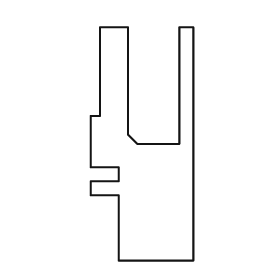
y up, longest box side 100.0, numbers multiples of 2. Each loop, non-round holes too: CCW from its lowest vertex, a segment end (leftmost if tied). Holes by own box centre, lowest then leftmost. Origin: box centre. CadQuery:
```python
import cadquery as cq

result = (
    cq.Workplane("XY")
    .moveTo(-10.0, -50.0)
    .lineTo(22.0, -50.0)
    .lineTo(22.0, 50.0)
    .lineTo(16.0, 50.0)
    .lineTo(16.0, 0.0)
    .lineTo(-2.0, 0.0)
    .lineTo(-6.0, 4.0)
    .lineTo(-6.0, 50.0)
    .lineTo(-18.0, 50.0)
    .lineTo(-18.0, 12.0)
    .lineTo(-22.0, 12.0)
    .lineTo(-22.0, -10.0)
    .lineTo(-10.0, -10.0)
    .lineTo(-10.0, -16.0)
    .lineTo(-22.0, -16.0)
    .lineTo(-22.0, -22.0)
    .lineTo(-10.0, -22.0)
    .close()
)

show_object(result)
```